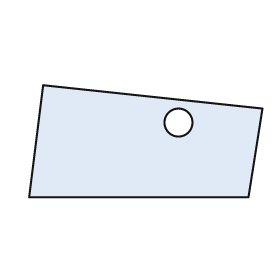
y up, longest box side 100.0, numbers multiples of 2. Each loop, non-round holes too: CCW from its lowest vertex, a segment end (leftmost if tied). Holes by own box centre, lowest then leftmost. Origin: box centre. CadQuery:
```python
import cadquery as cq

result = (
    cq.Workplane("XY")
    .moveTo(-50.0, -24.0)
    .lineTo(44.0, -24.0)
    .lineTo(50.0, 14.0)
    .lineTo(-44.0, 24.0)
    .close()
    .moveTo(14.0, 8.0)
    .circle(6.0)
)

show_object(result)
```